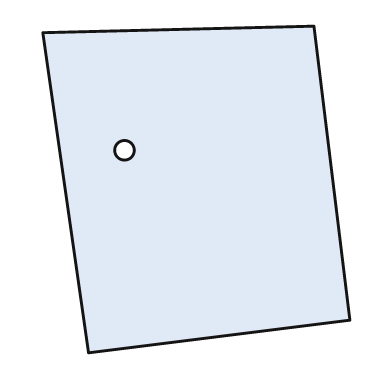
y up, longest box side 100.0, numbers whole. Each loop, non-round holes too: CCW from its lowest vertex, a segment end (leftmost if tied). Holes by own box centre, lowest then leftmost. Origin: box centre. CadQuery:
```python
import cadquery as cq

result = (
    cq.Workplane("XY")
    .moveTo(-33.0, -50.0)
    .lineTo(47.0, -40.0)
    .lineTo(36.0, 50.0)
    .lineTo(-47.0, 48.0)
    .close()
    .moveTo(-22.0, 12.0)
    .circle(3.0)
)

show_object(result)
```